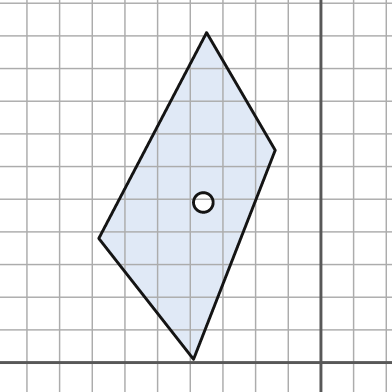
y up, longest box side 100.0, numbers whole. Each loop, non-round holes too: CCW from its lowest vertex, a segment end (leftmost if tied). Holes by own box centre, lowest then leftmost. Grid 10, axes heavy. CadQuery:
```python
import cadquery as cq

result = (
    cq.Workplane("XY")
    .moveTo(-39.0, 1.0)
    .lineTo(-14.0, 65.0)
    .lineTo(-35.0, 101.0)
    .lineTo(-68.0, 38.0)
    .close()
    .moveTo(-36.0, 49.0)
    .circle(3.0)
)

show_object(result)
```